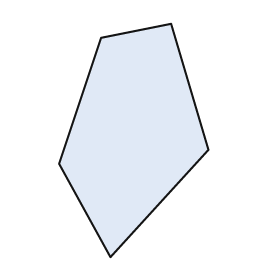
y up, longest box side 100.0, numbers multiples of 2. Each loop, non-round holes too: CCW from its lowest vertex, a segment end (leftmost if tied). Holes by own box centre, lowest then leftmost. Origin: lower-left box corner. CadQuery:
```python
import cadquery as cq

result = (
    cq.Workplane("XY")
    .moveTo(22.0, 0.0)
    .lineTo(64.0, 46.0)
    .lineTo(48.0, 100.0)
    .lineTo(18.0, 94.0)
    .lineTo(0.0, 40.0)
    .close()
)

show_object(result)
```